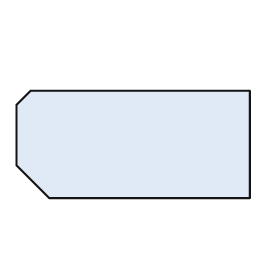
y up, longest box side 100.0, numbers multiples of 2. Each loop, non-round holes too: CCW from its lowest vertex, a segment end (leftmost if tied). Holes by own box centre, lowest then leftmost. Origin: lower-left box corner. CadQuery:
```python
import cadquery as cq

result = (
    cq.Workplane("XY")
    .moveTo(14.0, 0.0)
    .lineTo(100.0, 0.0)
    .lineTo(100.0, 46.0)
    .lineTo(6.0, 46.0)
    .lineTo(0.0, 40.0)
    .lineTo(0.0, 14.0)
    .close()
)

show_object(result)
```